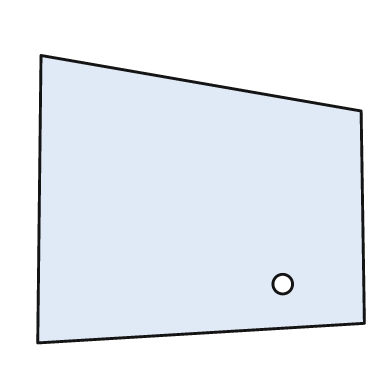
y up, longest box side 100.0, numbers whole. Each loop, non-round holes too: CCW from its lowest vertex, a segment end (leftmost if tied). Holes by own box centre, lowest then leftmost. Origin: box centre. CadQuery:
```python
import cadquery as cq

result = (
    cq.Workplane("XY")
    .moveTo(-50.0, -44.0)
    .lineTo(50.0, -38.0)
    .lineTo(49.0, 27.0)
    .lineTo(-49.0, 44.0)
    .close()
    .moveTo(25.0, -26.0)
    .circle(3.0)
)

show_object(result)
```